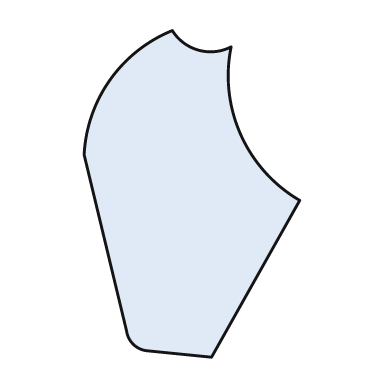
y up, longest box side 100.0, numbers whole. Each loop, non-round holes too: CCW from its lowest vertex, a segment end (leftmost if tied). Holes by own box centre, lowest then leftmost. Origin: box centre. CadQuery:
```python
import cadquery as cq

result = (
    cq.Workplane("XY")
    .moveTo(6.0, -50.0)
    .lineTo(33.0, -2.0)
    .threePointArc((15.0, 18.0), (12.0, 45.0))
    .threePointArc((2.0, 44.0), (-6.0, 50.0))
    .threePointArc((-25.0, 35.0), (-33.0, 12.0))
    .lineTo(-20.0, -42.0)
    .threePointArc((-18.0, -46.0), (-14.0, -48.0))
    .close()
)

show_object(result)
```